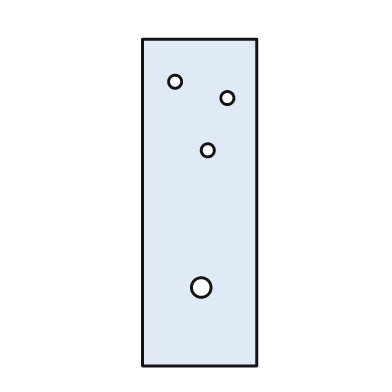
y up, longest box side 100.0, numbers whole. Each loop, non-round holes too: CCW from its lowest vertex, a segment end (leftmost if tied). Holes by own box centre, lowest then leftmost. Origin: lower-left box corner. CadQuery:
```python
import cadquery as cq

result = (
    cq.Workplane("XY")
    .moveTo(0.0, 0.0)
    .lineTo(35.0, 0.0)
    .lineTo(35.0, 100.0)
    .lineTo(0.0, 100.0)
    .close()
    .moveTo(18.0, 24.0)
    .circle(3.0)
    .moveTo(20.0, 66.0)
    .circle(2.0)
    .moveTo(26.0, 82.0)
    .circle(2.0)
    .moveTo(10.0, 87.0)
    .circle(2.0)
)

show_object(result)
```